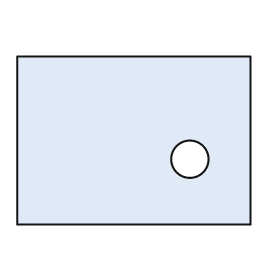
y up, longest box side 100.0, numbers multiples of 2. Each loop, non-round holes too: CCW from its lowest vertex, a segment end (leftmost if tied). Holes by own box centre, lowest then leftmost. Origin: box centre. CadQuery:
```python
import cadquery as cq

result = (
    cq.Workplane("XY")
    .moveTo(-50.0, -36.0)
    .lineTo(50.0, -36.0)
    .lineTo(50.0, 36.0)
    .lineTo(-50.0, 36.0)
    .close()
    .moveTo(24.0, -8.0)
    .circle(8.0)
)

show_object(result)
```